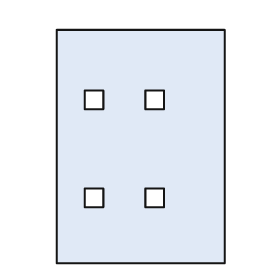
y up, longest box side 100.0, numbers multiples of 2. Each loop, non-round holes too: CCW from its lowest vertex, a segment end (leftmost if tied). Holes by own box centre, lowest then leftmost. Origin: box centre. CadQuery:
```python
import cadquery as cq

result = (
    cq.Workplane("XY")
    .moveTo(-36.0, -50.0)
    .lineTo(36.0, -50.0)
    .lineTo(36.0, 50.0)
    .lineTo(-36.0, 50.0)
    .close()
    .moveTo(-24.0, -26.0)
    .lineTo(-16.0, -26.0)
    .lineTo(-16.0, -18.0)
    .lineTo(-24.0, -18.0)
    .close()
    .moveTo(2.0, -26.0)
    .lineTo(10.0, -26.0)
    .lineTo(10.0, -18.0)
    .lineTo(2.0, -18.0)
    .close()
    .moveTo(-24.0, 16.0)
    .lineTo(-16.0, 16.0)
    .lineTo(-16.0, 24.0)
    .lineTo(-24.0, 24.0)
    .close()
    .moveTo(2.0, 16.0)
    .lineTo(10.0, 16.0)
    .lineTo(10.0, 24.0)
    .lineTo(2.0, 24.0)
    .close()
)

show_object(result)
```